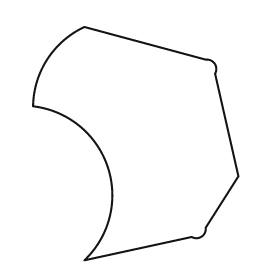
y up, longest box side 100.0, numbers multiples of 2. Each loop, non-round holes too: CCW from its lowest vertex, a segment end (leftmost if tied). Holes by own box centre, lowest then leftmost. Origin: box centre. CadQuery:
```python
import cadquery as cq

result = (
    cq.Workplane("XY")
    .moveTo(-22.0, -50.0)
    .lineTo(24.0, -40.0)
    .threePointArc((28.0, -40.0), (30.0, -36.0))
    .lineTo(44.0, -14.0)
    .lineTo(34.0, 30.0)
    .threePointArc((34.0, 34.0), (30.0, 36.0))
    .lineTo(-22.0, 50.0)
    .threePointArc((-38.0, 36.0), (-44.0, 16.0))
    .threePointArc((-12.0, -10.0), (-22.0, -50.0))
    .close()
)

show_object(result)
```